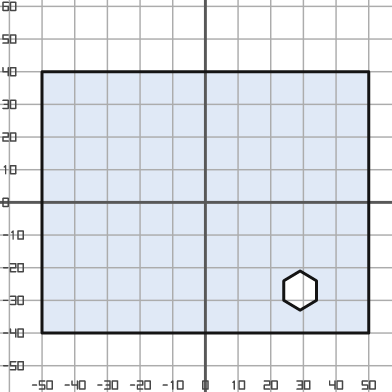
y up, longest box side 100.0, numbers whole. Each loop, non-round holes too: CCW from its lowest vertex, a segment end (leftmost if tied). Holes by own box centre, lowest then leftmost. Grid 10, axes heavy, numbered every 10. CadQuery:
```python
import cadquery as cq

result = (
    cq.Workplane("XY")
    .moveTo(-50.0, -40.0)
    .lineTo(50.0, -40.0)
    .lineTo(50.0, 40.0)
    .lineTo(-50.0, 40.0)
    .close()
    .moveTo(29.0, -33.0)
    .lineTo(34.0, -30.0)
    .lineTo(34.0, -24.0)
    .lineTo(29.0, -21.0)
    .lineTo(24.0, -24.0)
    .lineTo(24.0, -30.0)
    .close()
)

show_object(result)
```